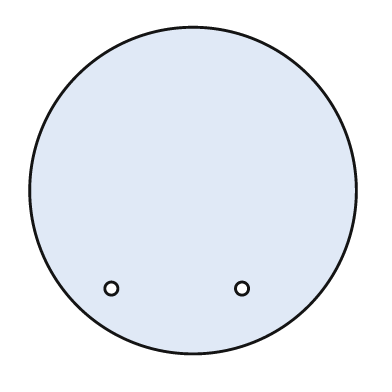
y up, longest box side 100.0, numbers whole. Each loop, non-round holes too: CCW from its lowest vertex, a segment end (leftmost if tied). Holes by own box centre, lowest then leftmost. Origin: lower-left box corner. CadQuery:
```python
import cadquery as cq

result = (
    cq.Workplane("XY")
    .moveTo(50.0, 50.0)
    .circle(50.0)
    .moveTo(25.0, 20.0)
    .circle(2.0)
    .moveTo(65.0, 20.0)
    .circle(2.0)
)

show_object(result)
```